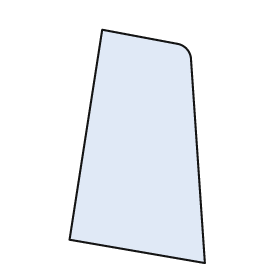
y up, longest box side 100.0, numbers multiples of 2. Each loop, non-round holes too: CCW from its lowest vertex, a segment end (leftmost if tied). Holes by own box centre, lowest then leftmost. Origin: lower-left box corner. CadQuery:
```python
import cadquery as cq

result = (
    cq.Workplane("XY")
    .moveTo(58.0, 0.0)
    .lineTo(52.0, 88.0)
    .threePointArc((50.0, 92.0), (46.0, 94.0))
    .lineTo(14.0, 100.0)
    .lineTo(0.0, 10.0)
    .close()
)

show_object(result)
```